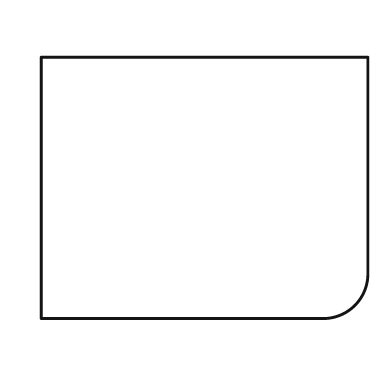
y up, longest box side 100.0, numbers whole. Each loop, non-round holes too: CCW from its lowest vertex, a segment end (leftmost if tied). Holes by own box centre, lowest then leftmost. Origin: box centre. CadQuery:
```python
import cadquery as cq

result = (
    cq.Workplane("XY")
    .moveTo(-50.0, -40.0)
    .lineTo(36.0, -40.0)
    .threePointArc((46.0, -36.0), (50.0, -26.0))
    .lineTo(50.0, 40.0)
    .lineTo(-50.0, 40.0)
    .close()
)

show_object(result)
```